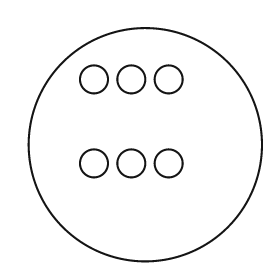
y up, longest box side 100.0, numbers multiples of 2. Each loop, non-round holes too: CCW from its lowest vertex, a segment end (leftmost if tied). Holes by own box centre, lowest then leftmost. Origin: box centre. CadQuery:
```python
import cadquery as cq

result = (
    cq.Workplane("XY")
    .moveTo(0.0, 0.0)
    .circle(50.0)
    .moveTo(-22.0, -8.0)
    .circle(6.0)
    .moveTo(-6.0, -8.0)
    .circle(6.0)
    .moveTo(10.0, -8.0)
    .circle(6.0)
    .moveTo(-22.0, 28.0)
    .circle(6.0)
    .moveTo(-6.0, 28.0)
    .circle(6.0)
    .moveTo(10.0, 28.0)
    .circle(6.0)
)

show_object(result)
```